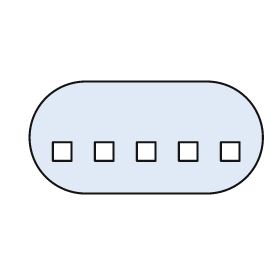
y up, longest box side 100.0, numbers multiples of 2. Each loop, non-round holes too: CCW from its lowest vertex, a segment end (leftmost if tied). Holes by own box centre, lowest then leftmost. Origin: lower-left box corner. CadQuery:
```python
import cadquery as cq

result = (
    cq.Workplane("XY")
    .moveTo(24.0, 0.0)
    .lineTo(76.0, 0.0)
    .threePointArc((100.0, 24.0), (76.0, 48.0))
    .lineTo(24.0, 48.0)
    .threePointArc((0.0, 24.0), (24.0, 0.0))
    .close()
    .moveTo(10.0, 14.0)
    .lineTo(18.0, 14.0)
    .lineTo(18.0, 22.0)
    .lineTo(10.0, 22.0)
    .close()
    .moveTo(28.0, 14.0)
    .lineTo(36.0, 14.0)
    .lineTo(36.0, 22.0)
    .lineTo(28.0, 22.0)
    .close()
    .moveTo(46.0, 14.0)
    .lineTo(54.0, 14.0)
    .lineTo(54.0, 22.0)
    .lineTo(46.0, 22.0)
    .close()
    .moveTo(64.0, 14.0)
    .lineTo(72.0, 14.0)
    .lineTo(72.0, 22.0)
    .lineTo(64.0, 22.0)
    .close()
    .moveTo(82.0, 14.0)
    .lineTo(90.0, 14.0)
    .lineTo(90.0, 22.0)
    .lineTo(82.0, 22.0)
    .close()
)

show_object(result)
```